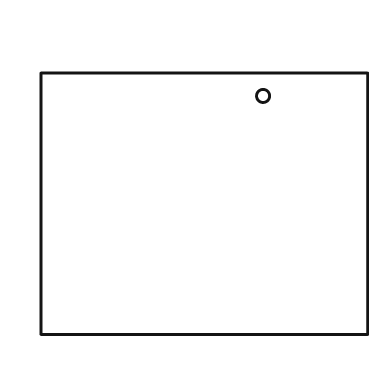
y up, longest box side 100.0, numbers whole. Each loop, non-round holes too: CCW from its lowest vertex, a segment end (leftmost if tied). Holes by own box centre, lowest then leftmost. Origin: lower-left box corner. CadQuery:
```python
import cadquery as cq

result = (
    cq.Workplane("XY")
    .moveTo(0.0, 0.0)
    .lineTo(100.0, 0.0)
    .lineTo(100.0, 80.0)
    .lineTo(0.0, 80.0)
    .close()
    .moveTo(68.0, 73.0)
    .circle(2.0)
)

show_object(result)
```